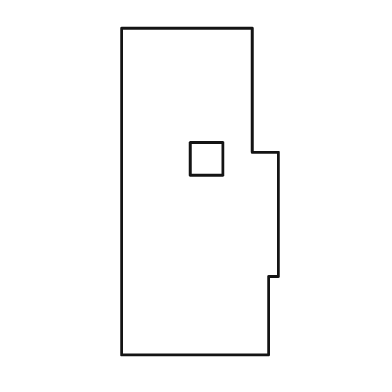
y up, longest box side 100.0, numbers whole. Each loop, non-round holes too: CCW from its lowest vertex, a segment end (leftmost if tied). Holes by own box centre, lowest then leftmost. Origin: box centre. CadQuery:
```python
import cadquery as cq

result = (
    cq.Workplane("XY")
    .moveTo(-24.0, -50.0)
    .lineTo(21.0, -50.0)
    .lineTo(21.0, -26.0)
    .lineTo(24.0, -26.0)
    .lineTo(24.0, 12.0)
    .lineTo(16.0, 12.0)
    .lineTo(16.0, 50.0)
    .lineTo(-24.0, 50.0)
    .close()
    .moveTo(-3.0, 5.0)
    .lineTo(7.0, 5.0)
    .lineTo(7.0, 15.0)
    .lineTo(-3.0, 15.0)
    .close()
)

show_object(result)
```